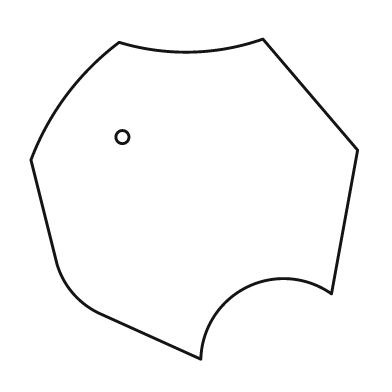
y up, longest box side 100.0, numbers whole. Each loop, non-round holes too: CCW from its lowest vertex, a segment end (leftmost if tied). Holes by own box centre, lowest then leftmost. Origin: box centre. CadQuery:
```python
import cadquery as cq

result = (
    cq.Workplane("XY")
    .moveTo(2.0, -49.0)
    .threePointArc((16.0, -27.0), (42.0, -29.0))
    .lineTo(50.0, 15.0)
    .lineTo(21.0, 49.0)
    .threePointArc((-1.0, 45.0), (-23.0, 48.0))
    .threePointArc((-39.0, 32.0), (-50.0, 12.0))
    .lineTo(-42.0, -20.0)
    .threePointArc((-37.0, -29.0), (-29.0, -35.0))
    .close()
    .moveTo(-22.0, 19.0)
    .circle(2.0)
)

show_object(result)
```